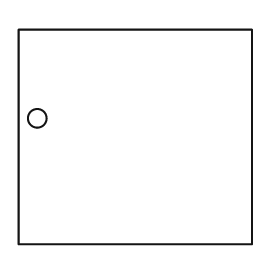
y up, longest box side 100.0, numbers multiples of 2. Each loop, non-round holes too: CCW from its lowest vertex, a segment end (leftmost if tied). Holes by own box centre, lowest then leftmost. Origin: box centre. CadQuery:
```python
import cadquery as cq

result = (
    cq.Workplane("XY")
    .moveTo(-50.0, -46.0)
    .lineTo(50.0, -46.0)
    .lineTo(50.0, 46.0)
    .lineTo(-50.0, 46.0)
    .close()
    .moveTo(-42.0, 8.0)
    .circle(4.0)
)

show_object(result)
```